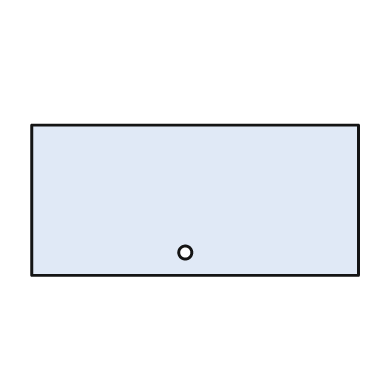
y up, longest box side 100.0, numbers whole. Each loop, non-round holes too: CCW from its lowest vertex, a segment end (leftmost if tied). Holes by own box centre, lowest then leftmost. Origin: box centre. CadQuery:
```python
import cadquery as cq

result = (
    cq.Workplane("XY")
    .moveTo(-50.0, -23.0)
    .lineTo(50.0, -23.0)
    .lineTo(50.0, 23.0)
    .lineTo(-50.0, 23.0)
    .close()
    .moveTo(-3.0, -16.0)
    .circle(2.0)
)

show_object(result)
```